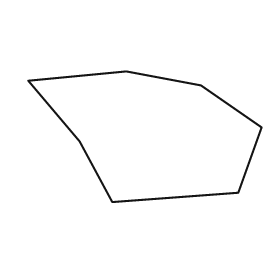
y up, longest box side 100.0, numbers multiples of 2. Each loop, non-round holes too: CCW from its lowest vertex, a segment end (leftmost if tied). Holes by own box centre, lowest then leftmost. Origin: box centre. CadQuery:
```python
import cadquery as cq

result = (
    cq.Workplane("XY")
    .moveTo(-14.0, -28.0)
    .lineTo(40.0, -24.0)
    .lineTo(50.0, 4.0)
    .lineTo(24.0, 22.0)
    .lineTo(-8.0, 28.0)
    .lineTo(-50.0, 24.0)
    .lineTo(-28.0, -2.0)
    .close()
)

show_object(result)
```